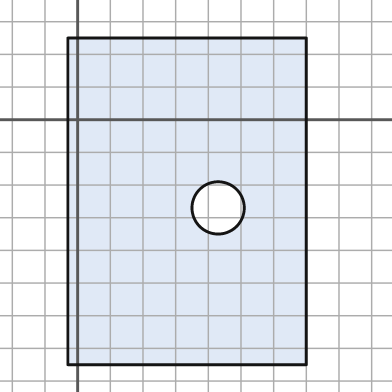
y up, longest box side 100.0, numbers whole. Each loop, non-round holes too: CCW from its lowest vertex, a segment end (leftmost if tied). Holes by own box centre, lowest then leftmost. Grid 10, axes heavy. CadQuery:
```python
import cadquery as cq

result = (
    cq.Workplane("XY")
    .moveTo(-3.0, -75.0)
    .lineTo(70.0, -75.0)
    .lineTo(70.0, 25.0)
    .lineTo(-3.0, 25.0)
    .close()
    .moveTo(43.0, -27.0)
    .circle(8.0)
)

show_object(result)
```